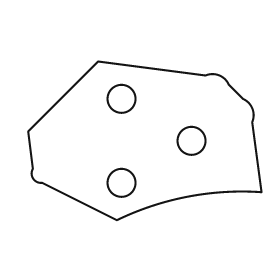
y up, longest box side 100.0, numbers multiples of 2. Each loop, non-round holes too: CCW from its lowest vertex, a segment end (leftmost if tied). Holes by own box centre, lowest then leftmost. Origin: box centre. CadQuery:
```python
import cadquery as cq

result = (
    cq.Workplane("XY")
    .moveTo(-12.0, -34.0)
    .threePointArc((18.0, -24.0), (50.0, -22.0))
    .lineTo(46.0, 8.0)
    .threePointArc((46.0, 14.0), (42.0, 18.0))
    .lineTo(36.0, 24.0)
    .threePointArc((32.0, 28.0), (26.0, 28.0))
    .lineTo(-20.0, 34.0)
    .lineTo(-50.0, 4.0)
    .lineTo(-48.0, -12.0)
    .threePointArc((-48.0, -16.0), (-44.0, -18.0))
    .close()
    .moveTo(-10.0, -18.0)
    .circle(6.0)
    .moveTo(20.0, 0.0)
    .circle(6.0)
    .moveTo(-10.0, 18.0)
    .circle(6.0)
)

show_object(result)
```